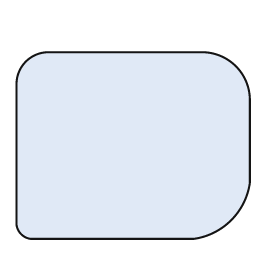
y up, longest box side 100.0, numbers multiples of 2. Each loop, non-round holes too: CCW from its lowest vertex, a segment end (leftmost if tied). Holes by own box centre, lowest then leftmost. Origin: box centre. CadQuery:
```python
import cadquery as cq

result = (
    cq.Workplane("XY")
    .moveTo(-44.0, -40.0)
    .lineTo(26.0, -40.0)
    .threePointArc((42.0, -32.0), (50.0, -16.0))
    .lineTo(50.0, 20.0)
    .threePointArc((44.0, 34.0), (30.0, 40.0))
    .lineTo(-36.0, 40.0)
    .threePointArc((-46.0, 36.0), (-50.0, 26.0))
    .lineTo(-50.0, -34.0)
    .threePointArc((-48.0, -38.0), (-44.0, -40.0))
    .close()
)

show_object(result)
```